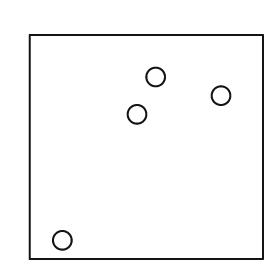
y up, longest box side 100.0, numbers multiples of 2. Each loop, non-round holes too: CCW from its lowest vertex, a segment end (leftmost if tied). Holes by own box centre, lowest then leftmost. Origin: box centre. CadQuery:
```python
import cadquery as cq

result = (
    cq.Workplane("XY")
    .moveTo(-50.0, -48.0)
    .lineTo(50.0, -48.0)
    .lineTo(50.0, 48.0)
    .lineTo(-50.0, 48.0)
    .close()
    .moveTo(-36.0, -40.0)
    .circle(4.0)
    .moveTo(-4.0, 14.0)
    .circle(4.0)
    .moveTo(32.0, 22.0)
    .circle(4.0)
    .moveTo(4.0, 30.0)
    .circle(4.0)
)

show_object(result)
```